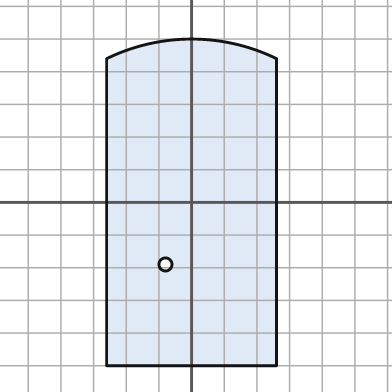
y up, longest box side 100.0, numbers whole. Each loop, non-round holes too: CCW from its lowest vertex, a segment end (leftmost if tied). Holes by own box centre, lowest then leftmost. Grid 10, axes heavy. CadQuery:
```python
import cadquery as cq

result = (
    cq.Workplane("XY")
    .moveTo(-26.0, -50.0)
    .lineTo(26.0, -50.0)
    .lineTo(26.0, 44.0)
    .threePointArc((0.0, 50.0), (-26.0, 44.0))
    .close()
    .moveTo(-8.0, -19.0)
    .circle(2.0)
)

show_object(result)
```